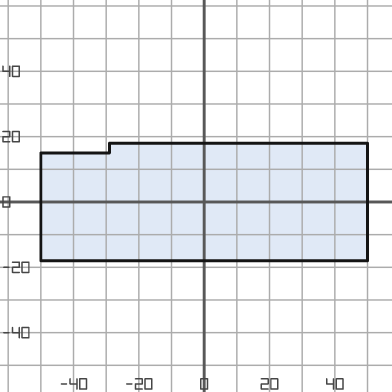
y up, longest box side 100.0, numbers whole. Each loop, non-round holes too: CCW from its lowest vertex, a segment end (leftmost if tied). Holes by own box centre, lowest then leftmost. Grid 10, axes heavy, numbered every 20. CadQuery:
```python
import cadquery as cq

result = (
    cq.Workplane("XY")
    .moveTo(-50.0, -18.0)
    .lineTo(50.0, -18.0)
    .lineTo(50.0, 18.0)
    .lineTo(-29.0, 18.0)
    .lineTo(-29.0, 15.0)
    .lineTo(-50.0, 15.0)
    .close()
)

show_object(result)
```